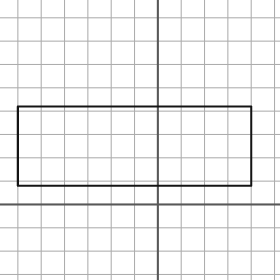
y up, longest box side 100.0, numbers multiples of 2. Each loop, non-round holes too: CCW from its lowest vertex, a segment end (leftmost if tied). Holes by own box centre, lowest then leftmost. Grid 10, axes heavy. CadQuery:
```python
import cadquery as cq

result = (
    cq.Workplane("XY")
    .moveTo(-60.0, 8.0)
    .lineTo(40.0, 8.0)
    .lineTo(40.0, 42.0)
    .lineTo(-60.0, 42.0)
    .close()
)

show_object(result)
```